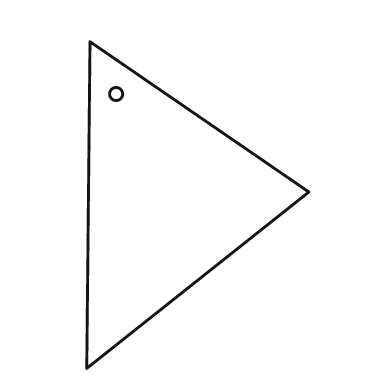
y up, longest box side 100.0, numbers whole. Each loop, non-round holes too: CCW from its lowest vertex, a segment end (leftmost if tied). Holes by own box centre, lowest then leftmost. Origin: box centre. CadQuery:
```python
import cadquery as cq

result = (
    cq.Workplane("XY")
    .moveTo(-34.0, -50.0)
    .lineTo(34.0, 4.0)
    .lineTo(-33.0, 50.0)
    .close()
    .moveTo(-25.0, 34.0)
    .circle(2.0)
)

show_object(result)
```